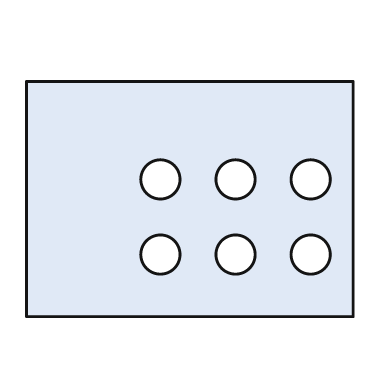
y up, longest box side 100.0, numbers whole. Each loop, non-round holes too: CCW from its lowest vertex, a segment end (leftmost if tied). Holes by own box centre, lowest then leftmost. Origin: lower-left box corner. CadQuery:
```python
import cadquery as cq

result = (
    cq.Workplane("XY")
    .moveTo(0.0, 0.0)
    .lineTo(100.0, 0.0)
    .lineTo(100.0, 72.0)
    .lineTo(0.0, 72.0)
    .close()
    .moveTo(41.0, 19.0)
    .circle(6.0)
    .moveTo(64.0, 19.0)
    .circle(6.0)
    .moveTo(87.0, 19.0)
    .circle(6.0)
    .moveTo(41.0, 42.0)
    .circle(6.0)
    .moveTo(64.0, 42.0)
    .circle(6.0)
    .moveTo(87.0, 42.0)
    .circle(6.0)
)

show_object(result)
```